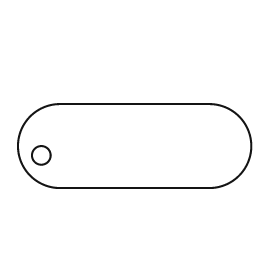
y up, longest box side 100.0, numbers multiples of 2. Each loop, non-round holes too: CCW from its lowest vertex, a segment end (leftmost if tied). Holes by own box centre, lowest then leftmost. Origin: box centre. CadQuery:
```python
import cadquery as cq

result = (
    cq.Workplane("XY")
    .moveTo(-32.0, -18.0)
    .lineTo(32.0, -18.0)
    .threePointArc((50.0, 0.0), (32.0, 18.0))
    .lineTo(-32.0, 18.0)
    .threePointArc((-50.0, 0.0), (-32.0, -18.0))
    .close()
    .moveTo(-40.0, -4.0)
    .circle(4.0)
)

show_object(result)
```